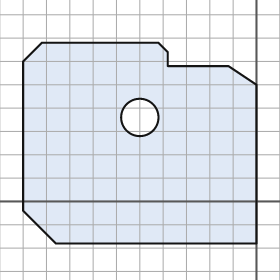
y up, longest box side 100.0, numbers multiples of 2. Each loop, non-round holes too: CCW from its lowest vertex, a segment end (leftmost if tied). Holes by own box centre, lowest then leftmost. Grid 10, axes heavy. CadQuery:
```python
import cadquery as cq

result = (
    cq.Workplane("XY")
    .moveTo(-86.0, -18.0)
    .lineTo(0.0, -18.0)
    .lineTo(0.0, 50.0)
    .lineTo(-12.0, 58.0)
    .lineTo(-38.0, 58.0)
    .lineTo(-38.0, 64.0)
    .lineTo(-42.0, 68.0)
    .lineTo(-92.0, 68.0)
    .lineTo(-100.0, 60.0)
    .lineTo(-100.0, -4.0)
    .close()
    .moveTo(-50.0, 36.0)
    .circle(8.0)
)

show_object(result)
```